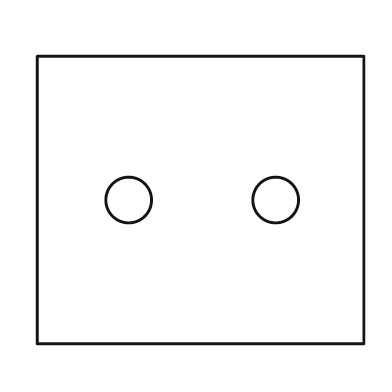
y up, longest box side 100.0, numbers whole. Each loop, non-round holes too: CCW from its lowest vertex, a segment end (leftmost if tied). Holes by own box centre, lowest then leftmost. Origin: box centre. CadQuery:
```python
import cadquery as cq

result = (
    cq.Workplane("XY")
    .moveTo(-50.0, -44.0)
    .lineTo(50.0, -44.0)
    .lineTo(50.0, 44.0)
    .lineTo(-50.0, 44.0)
    .close()
    .moveTo(-22.0, 0.0)
    .circle(7.0)
    .moveTo(23.0, 0.0)
    .circle(7.0)
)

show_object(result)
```